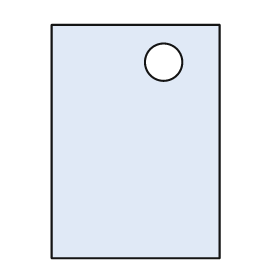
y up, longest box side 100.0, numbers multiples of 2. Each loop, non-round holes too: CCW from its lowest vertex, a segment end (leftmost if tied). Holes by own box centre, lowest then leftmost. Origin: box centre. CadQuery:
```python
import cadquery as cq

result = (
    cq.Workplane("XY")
    .moveTo(-36.0, -50.0)
    .lineTo(36.0, -50.0)
    .lineTo(36.0, 50.0)
    .lineTo(-36.0, 50.0)
    .close()
    .moveTo(12.0, 34.0)
    .circle(8.0)
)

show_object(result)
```